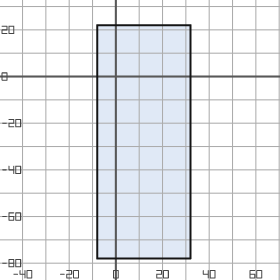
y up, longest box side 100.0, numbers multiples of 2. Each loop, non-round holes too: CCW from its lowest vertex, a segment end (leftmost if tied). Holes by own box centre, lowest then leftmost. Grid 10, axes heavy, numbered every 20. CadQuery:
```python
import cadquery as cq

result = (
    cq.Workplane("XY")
    .moveTo(-8.0, -78.0)
    .lineTo(32.0, -78.0)
    .lineTo(32.0, 22.0)
    .lineTo(-8.0, 22.0)
    .close()
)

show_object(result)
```